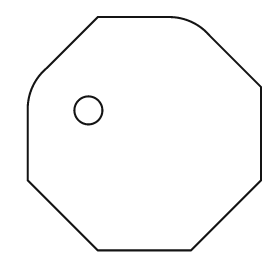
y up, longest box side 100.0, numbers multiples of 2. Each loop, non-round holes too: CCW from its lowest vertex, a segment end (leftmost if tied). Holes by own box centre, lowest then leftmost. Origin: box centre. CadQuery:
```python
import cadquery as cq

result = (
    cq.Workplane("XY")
    .moveTo(-20.0, -50.0)
    .lineTo(20.0, -50.0)
    .lineTo(50.0, -20.0)
    .lineTo(50.0, 20.0)
    .lineTo(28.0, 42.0)
    .threePointArc((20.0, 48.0), (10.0, 50.0))
    .lineTo(-20.0, 50.0)
    .lineTo(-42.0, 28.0)
    .threePointArc((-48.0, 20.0), (-50.0, 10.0))
    .lineTo(-50.0, -20.0)
    .close()
    .moveTo(-24.0, 10.0)
    .circle(6.0)
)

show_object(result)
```